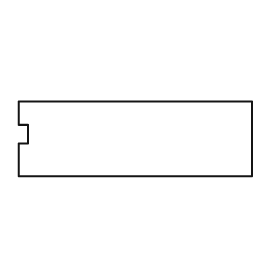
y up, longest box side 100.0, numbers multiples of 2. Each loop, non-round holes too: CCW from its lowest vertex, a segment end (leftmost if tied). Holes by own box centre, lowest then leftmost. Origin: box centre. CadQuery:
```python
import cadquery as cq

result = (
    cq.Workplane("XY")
    .moveTo(-50.0, -16.0)
    .lineTo(50.0, -16.0)
    .lineTo(50.0, 16.0)
    .lineTo(-50.0, 16.0)
    .lineTo(-50.0, 6.0)
    .lineTo(-46.0, 6.0)
    .lineTo(-46.0, -2.0)
    .lineTo(-50.0, -2.0)
    .close()
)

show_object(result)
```